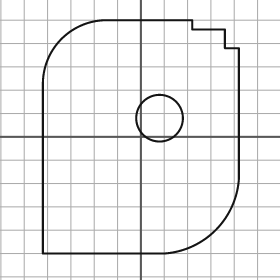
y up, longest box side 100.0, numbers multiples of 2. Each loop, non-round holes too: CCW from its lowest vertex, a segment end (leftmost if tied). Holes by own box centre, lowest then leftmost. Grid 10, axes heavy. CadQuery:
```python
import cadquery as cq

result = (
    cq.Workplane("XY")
    .moveTo(-42.0, -50.0)
    .lineTo(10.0, -50.0)
    .threePointArc((32.0, -40.0), (42.0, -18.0))
    .lineTo(42.0, 38.0)
    .lineTo(36.0, 38.0)
    .lineTo(36.0, 46.0)
    .lineTo(22.0, 46.0)
    .lineTo(22.0, 50.0)
    .lineTo(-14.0, 50.0)
    .threePointArc((-34.0, 42.0), (-42.0, 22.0))
    .close()
    .moveTo(8.0, 8.0)
    .circle(10.0)
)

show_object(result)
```